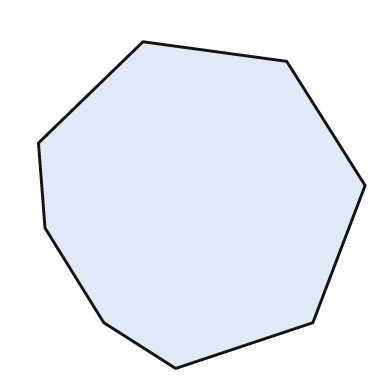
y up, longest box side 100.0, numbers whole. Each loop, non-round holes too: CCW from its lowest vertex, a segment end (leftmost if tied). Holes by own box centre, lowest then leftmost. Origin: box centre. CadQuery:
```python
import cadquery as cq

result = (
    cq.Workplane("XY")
    .moveTo(-8.0, -50.0)
    .lineTo(34.0, -36.0)
    .lineTo(50.0, 6.0)
    .lineTo(26.0, 44.0)
    .lineTo(-18.0, 50.0)
    .lineTo(-50.0, 19.0)
    .lineTo(-48.0, -7.0)
    .lineTo(-30.0, -36.0)
    .close()
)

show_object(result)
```